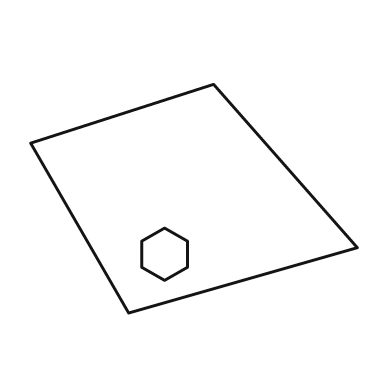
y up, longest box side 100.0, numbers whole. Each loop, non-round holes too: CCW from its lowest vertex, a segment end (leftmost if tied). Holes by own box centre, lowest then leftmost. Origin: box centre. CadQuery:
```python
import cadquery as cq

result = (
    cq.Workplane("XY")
    .moveTo(-20.0, -35.0)
    .lineTo(50.0, -15.0)
    .lineTo(6.0, 35.0)
    .lineTo(-50.0, 17.0)
    .close()
    .moveTo(-9.0, -25.0)
    .lineTo(-2.0, -21.0)
    .lineTo(-2.0, -13.0)
    .lineTo(-9.0, -9.0)
    .lineTo(-16.0, -13.0)
    .lineTo(-16.0, -21.0)
    .close()
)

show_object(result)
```